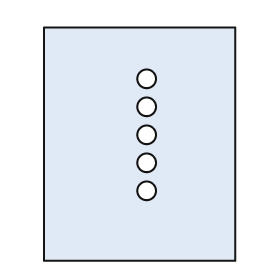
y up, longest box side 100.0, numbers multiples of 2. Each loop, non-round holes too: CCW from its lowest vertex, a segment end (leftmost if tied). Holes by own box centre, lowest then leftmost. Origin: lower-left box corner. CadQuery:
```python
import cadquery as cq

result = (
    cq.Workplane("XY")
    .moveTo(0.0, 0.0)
    .lineTo(82.0, 0.0)
    .lineTo(82.0, 100.0)
    .lineTo(0.0, 100.0)
    .close()
    .moveTo(44.0, 30.0)
    .circle(4.0)
    .moveTo(44.0, 42.0)
    .circle(4.0)
    .moveTo(44.0, 54.0)
    .circle(4.0)
    .moveTo(44.0, 66.0)
    .circle(4.0)
    .moveTo(44.0, 78.0)
    .circle(4.0)
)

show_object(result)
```